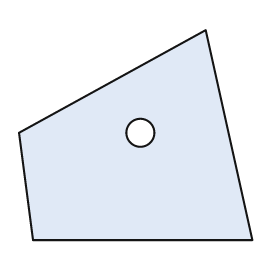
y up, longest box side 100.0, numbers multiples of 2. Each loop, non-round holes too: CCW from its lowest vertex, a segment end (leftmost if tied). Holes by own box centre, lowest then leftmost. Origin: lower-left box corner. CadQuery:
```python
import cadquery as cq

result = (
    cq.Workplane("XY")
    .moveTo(6.0, 0.0)
    .lineTo(100.0, 0.0)
    .lineTo(80.0, 90.0)
    .lineTo(0.0, 46.0)
    .close()
    .moveTo(52.0, 46.0)
    .circle(6.0)
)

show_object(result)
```